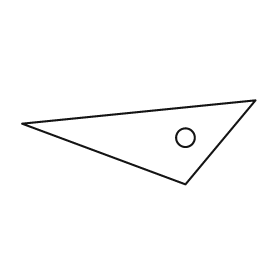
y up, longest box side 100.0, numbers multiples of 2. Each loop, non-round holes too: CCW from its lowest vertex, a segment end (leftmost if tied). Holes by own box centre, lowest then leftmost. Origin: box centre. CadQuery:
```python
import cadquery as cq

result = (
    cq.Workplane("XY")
    .moveTo(20.0, -18.0)
    .lineTo(50.0, 18.0)
    .lineTo(-50.0, 8.0)
    .close()
    .moveTo(20.0, 2.0)
    .circle(4.0)
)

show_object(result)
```